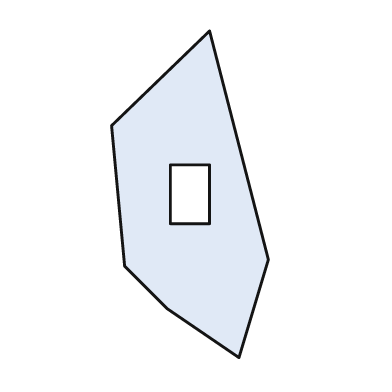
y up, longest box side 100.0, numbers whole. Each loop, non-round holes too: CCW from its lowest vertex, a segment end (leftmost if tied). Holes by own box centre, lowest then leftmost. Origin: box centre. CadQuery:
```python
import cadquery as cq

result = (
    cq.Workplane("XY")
    .moveTo(15.0, -50.0)
    .lineTo(24.0, -20.0)
    .lineTo(6.0, 50.0)
    .lineTo(-24.0, 21.0)
    .lineTo(-20.0, -22.0)
    .lineTo(-7.0, -35.0)
    .close()
    .moveTo(-6.0, -9.0)
    .lineTo(6.0, -9.0)
    .lineTo(6.0, 9.0)
    .lineTo(-6.0, 9.0)
    .close()
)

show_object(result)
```